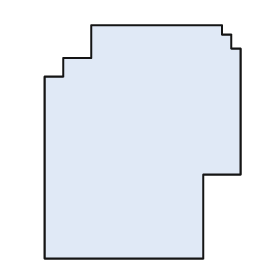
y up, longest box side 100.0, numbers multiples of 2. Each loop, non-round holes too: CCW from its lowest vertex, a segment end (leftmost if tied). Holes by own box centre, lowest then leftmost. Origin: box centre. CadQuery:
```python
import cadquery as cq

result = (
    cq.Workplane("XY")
    .moveTo(-42.0, -50.0)
    .lineTo(26.0, -50.0)
    .lineTo(26.0, -14.0)
    .lineTo(42.0, -14.0)
    .lineTo(42.0, 40.0)
    .lineTo(38.0, 40.0)
    .lineTo(38.0, 46.0)
    .lineTo(34.0, 46.0)
    .lineTo(34.0, 50.0)
    .lineTo(-22.0, 50.0)
    .lineTo(-22.0, 36.0)
    .lineTo(-34.0, 36.0)
    .lineTo(-34.0, 28.0)
    .lineTo(-42.0, 28.0)
    .close()
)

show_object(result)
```